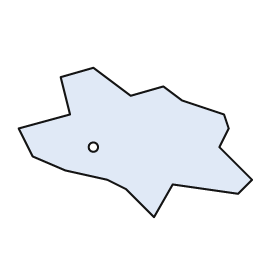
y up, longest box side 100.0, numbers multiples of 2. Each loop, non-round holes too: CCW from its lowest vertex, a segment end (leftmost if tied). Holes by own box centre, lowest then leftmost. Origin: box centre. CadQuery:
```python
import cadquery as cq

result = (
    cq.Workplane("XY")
    .moveTo(8.0, -32.0)
    .lineTo(16.0, -18.0)
    .lineTo(44.0, -22.0)
    .lineTo(50.0, -16.0)
    .lineTo(36.0, -2.0)
    .lineTo(40.0, 6.0)
    .lineTo(38.0, 12.0)
    .lineTo(20.0, 18.0)
    .lineTo(12.0, 24.0)
    .lineTo(-2.0, 20.0)
    .lineTo(-18.0, 32.0)
    .lineTo(-32.0, 28.0)
    .lineTo(-28.0, 12.0)
    .lineTo(-50.0, 6.0)
    .lineTo(-44.0, -6.0)
    .lineTo(-30.0, -12.0)
    .lineTo(-12.0, -16.0)
    .lineTo(-4.0, -20.0)
    .close()
    .moveTo(-18.0, -2.0)
    .circle(2.0)
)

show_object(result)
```